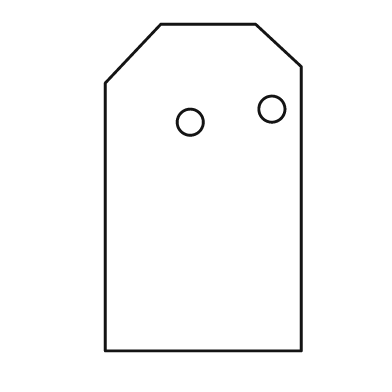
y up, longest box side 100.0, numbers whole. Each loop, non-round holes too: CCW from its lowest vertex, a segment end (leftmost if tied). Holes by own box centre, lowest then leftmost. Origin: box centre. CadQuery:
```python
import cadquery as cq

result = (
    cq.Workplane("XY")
    .moveTo(-30.0, -50.0)
    .lineTo(30.0, -50.0)
    .lineTo(30.0, 37.0)
    .lineTo(16.0, 50.0)
    .lineTo(-13.0, 50.0)
    .lineTo(-30.0, 32.0)
    .close()
    .moveTo(-4.0, 20.0)
    .circle(4.0)
    .moveTo(21.0, 24.0)
    .circle(4.0)
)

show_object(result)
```